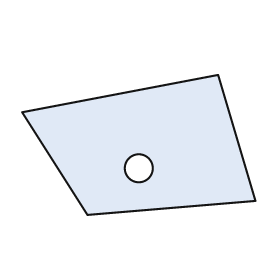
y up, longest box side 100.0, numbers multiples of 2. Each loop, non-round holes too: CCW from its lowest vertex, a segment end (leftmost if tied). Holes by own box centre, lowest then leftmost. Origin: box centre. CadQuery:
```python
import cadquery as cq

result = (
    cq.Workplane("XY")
    .moveTo(-22.0, -30.0)
    .lineTo(50.0, -24.0)
    .lineTo(34.0, 30.0)
    .lineTo(-50.0, 14.0)
    .close()
    .moveTo(0.0, -10.0)
    .circle(6.0)
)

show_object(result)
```